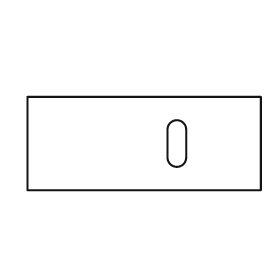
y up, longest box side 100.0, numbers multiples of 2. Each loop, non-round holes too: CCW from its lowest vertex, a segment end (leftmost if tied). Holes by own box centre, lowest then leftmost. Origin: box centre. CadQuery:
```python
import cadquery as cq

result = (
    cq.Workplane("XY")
    .moveTo(-50.0, -20.0)
    .lineTo(50.0, -20.0)
    .lineTo(50.0, 20.0)
    .lineTo(-50.0, 20.0)
    .close()
    .moveTo(10.0, -6.0)
    .threePointArc((14.0, -10.0), (18.0, -6.0))
    .lineTo(18.0, 6.0)
    .threePointArc((14.0, 10.0), (10.0, 6.0))
    .close()
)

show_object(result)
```